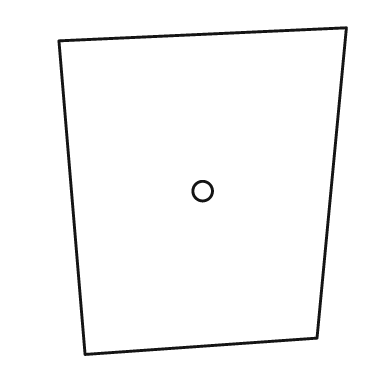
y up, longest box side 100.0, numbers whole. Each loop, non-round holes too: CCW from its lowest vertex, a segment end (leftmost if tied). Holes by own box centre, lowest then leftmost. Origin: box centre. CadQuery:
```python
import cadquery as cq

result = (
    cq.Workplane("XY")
    .moveTo(-36.0, -50.0)
    .lineTo(35.0, -45.0)
    .lineTo(44.0, 50.0)
    .lineTo(-44.0, 46.0)
    .close()
    .moveTo(0.0, 0.0)
    .circle(3.0)
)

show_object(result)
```